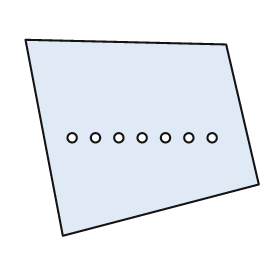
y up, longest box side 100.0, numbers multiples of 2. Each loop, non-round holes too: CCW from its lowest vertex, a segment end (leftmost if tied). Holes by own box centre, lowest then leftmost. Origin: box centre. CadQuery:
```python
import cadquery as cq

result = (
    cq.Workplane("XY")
    .moveTo(-34.0, -42.0)
    .lineTo(50.0, -20.0)
    .lineTo(36.0, 40.0)
    .lineTo(-50.0, 42.0)
    .close()
    .moveTo(-30.0, 0.0)
    .circle(2.0)
    .moveTo(-20.0, 0.0)
    .circle(2.0)
    .moveTo(-10.0, 0.0)
    .circle(2.0)
    .moveTo(0.0, 0.0)
    .circle(2.0)
    .moveTo(10.0, 0.0)
    .circle(2.0)
    .moveTo(20.0, 0.0)
    .circle(2.0)
    .moveTo(30.0, 0.0)
    .circle(2.0)
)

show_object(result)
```